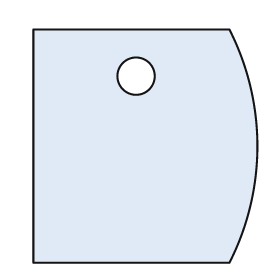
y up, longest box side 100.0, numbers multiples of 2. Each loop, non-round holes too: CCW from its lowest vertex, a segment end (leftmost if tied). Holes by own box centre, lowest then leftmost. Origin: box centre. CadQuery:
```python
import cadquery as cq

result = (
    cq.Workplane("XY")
    .moveTo(-48.0, -50.0)
    .lineTo(36.0, -50.0)
    .threePointArc((48.0, 0.0), (36.0, 50.0))
    .lineTo(-48.0, 50.0)
    .close()
    .moveTo(-4.0, 30.0)
    .circle(8.0)
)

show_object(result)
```